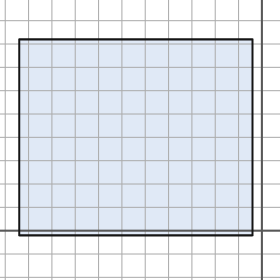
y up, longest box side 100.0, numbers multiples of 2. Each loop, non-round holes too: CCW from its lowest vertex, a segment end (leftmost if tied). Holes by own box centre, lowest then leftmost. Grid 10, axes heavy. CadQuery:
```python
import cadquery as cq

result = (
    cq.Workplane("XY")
    .moveTo(-104.0, -2.0)
    .lineTo(-4.0, -2.0)
    .lineTo(-4.0, 82.0)
    .lineTo(-104.0, 82.0)
    .close()
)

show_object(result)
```